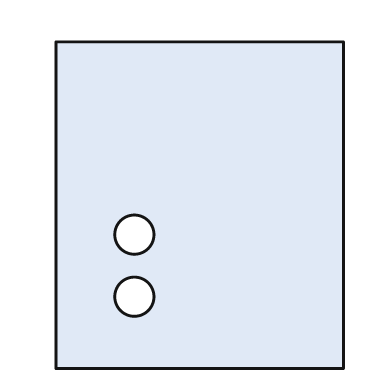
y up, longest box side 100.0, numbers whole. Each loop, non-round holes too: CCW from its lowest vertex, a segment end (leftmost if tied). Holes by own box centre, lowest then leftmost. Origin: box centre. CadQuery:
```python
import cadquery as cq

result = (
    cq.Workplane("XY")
    .moveTo(-44.0, -50.0)
    .lineTo(44.0, -50.0)
    .lineTo(44.0, 50.0)
    .lineTo(-44.0, 50.0)
    .close()
    .moveTo(-20.0, -28.0)
    .circle(6.0)
    .moveTo(-20.0, -9.0)
    .circle(6.0)
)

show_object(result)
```